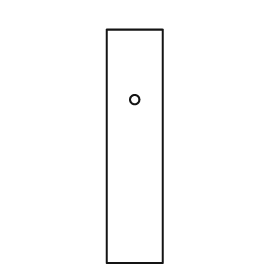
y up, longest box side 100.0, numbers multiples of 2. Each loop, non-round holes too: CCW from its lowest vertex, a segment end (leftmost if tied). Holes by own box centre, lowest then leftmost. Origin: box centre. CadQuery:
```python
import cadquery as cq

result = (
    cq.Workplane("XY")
    .moveTo(-12.0, -50.0)
    .lineTo(12.0, -50.0)
    .lineTo(12.0, 50.0)
    .lineTo(-12.0, 50.0)
    .close()
    .moveTo(0.0, 20.0)
    .circle(2.0)
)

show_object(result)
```